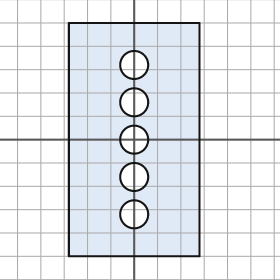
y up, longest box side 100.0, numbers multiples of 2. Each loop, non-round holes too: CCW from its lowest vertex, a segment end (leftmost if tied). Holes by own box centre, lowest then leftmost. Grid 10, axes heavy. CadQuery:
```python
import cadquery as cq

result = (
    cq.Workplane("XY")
    .moveTo(-28.0, -50.0)
    .lineTo(28.0, -50.0)
    .lineTo(28.0, 50.0)
    .lineTo(-28.0, 50.0)
    .close()
    .moveTo(0.0, -32.0)
    .circle(6.0)
    .moveTo(0.0, -16.0)
    .circle(6.0)
    .moveTo(0.0, 0.0)
    .circle(6.0)
    .moveTo(0.0, 16.0)
    .circle(6.0)
    .moveTo(0.0, 32.0)
    .circle(6.0)
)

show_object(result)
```